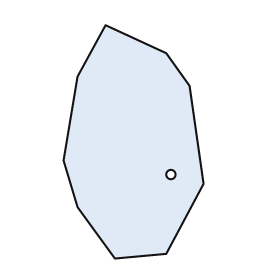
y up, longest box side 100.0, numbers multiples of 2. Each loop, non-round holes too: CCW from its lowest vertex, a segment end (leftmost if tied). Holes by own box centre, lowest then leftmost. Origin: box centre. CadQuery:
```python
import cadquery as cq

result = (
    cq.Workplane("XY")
    .moveTo(-8.0, -50.0)
    .lineTo(14.0, -48.0)
    .lineTo(30.0, -18.0)
    .lineTo(24.0, 24.0)
    .lineTo(14.0, 38.0)
    .lineTo(-12.0, 50.0)
    .lineTo(-24.0, 28.0)
    .lineTo(-30.0, -8.0)
    .lineTo(-24.0, -28.0)
    .close()
    .moveTo(16.0, -14.0)
    .circle(2.0)
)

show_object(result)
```